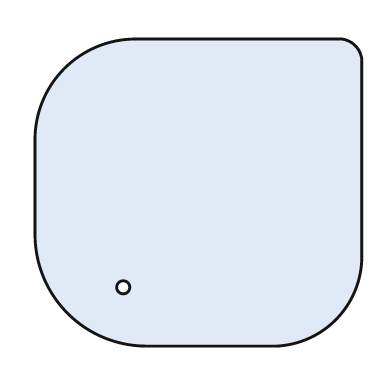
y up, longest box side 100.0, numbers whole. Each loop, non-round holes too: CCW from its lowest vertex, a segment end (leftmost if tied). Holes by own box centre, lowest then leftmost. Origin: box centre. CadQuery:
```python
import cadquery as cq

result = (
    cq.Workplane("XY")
    .moveTo(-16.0, -47.0)
    .lineTo(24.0, -47.0)
    .threePointArc((42.0, -39.0), (50.0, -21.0))
    .lineTo(50.0, 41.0)
    .threePointArc((48.0, 45.0), (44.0, 47.0))
    .lineTo(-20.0, 47.0)
    .threePointArc((-41.0, 38.0), (-50.0, 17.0))
    .lineTo(-50.0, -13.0)
    .threePointArc((-40.0, -37.0), (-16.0, -47.0))
    .close()
    .moveTo(-23.0, -29.0)
    .circle(2.0)
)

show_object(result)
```